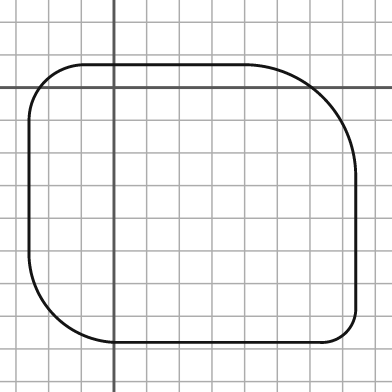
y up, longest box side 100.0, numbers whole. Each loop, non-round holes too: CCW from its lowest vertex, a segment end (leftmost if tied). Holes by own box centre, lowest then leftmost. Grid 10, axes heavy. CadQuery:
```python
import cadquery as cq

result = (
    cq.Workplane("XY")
    .moveTo(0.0, -78.0)
    .lineTo(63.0, -78.0)
    .threePointArc((71.0, -75.0), (74.0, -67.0))
    .lineTo(74.0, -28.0)
    .threePointArc((64.0, -3.0), (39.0, 7.0))
    .lineTo(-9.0, 7.0)
    .threePointArc((-21.0, 2.0), (-26.0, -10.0))
    .lineTo(-26.0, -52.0)
    .threePointArc((-18.0, -70.0), (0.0, -78.0))
    .close()
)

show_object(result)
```